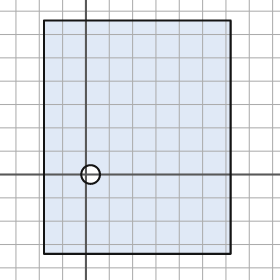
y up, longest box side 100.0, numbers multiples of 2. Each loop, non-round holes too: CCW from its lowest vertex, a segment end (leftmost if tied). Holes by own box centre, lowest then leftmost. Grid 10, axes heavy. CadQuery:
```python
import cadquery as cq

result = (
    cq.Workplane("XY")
    .moveTo(-18.0, -34.0)
    .lineTo(62.0, -34.0)
    .lineTo(62.0, 66.0)
    .lineTo(-18.0, 66.0)
    .close()
    .moveTo(2.0, 0.0)
    .circle(4.0)
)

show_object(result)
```